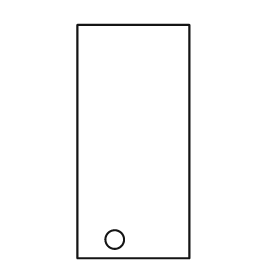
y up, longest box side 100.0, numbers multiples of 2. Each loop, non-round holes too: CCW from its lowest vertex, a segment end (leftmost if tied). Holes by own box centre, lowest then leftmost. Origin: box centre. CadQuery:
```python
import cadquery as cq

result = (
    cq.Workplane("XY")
    .moveTo(-24.0, -50.0)
    .lineTo(24.0, -50.0)
    .lineTo(24.0, 50.0)
    .lineTo(-24.0, 50.0)
    .close()
    .moveTo(-8.0, -42.0)
    .circle(4.0)
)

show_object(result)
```